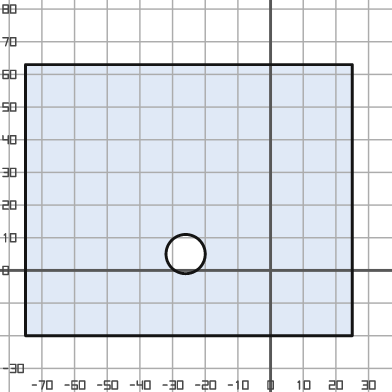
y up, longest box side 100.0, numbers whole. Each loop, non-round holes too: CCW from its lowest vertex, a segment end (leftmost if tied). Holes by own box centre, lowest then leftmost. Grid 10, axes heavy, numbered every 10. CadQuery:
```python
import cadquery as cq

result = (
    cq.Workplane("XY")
    .moveTo(-75.0, -20.0)
    .lineTo(25.0, -20.0)
    .lineTo(25.0, 63.0)
    .lineTo(-75.0, 63.0)
    .close()
    .moveTo(-26.0, 5.0)
    .circle(6.0)
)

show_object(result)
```